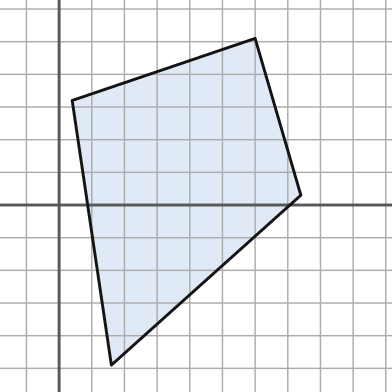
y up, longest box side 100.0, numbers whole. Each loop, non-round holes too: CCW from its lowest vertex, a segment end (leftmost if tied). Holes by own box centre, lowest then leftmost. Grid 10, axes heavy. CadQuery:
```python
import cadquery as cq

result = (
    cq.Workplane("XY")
    .moveTo(16.0, -49.0)
    .lineTo(74.0, 3.0)
    .lineTo(60.0, 51.0)
    .lineTo(4.0, 32.0)
    .close()
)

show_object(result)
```